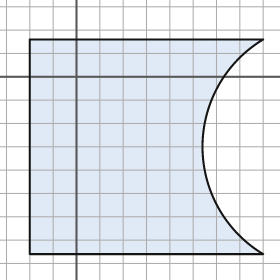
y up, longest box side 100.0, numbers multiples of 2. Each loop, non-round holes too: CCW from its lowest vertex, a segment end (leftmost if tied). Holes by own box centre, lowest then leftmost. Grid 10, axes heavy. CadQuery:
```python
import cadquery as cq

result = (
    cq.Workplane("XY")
    .moveTo(-20.0, -76.0)
    .lineTo(80.0, -76.0)
    .threePointArc((54.0, -30.0), (80.0, 16.0))
    .lineTo(-20.0, 16.0)
    .close()
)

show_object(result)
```